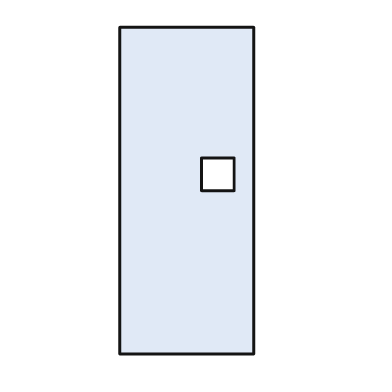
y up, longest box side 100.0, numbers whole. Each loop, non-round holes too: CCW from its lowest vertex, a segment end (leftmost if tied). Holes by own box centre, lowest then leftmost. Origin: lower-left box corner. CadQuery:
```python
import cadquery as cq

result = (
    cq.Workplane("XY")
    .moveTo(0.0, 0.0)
    .lineTo(41.0, 0.0)
    .lineTo(41.0, 100.0)
    .lineTo(0.0, 100.0)
    .close()
    .moveTo(25.0, 50.0)
    .lineTo(35.0, 50.0)
    .lineTo(35.0, 60.0)
    .lineTo(25.0, 60.0)
    .close()
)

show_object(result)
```